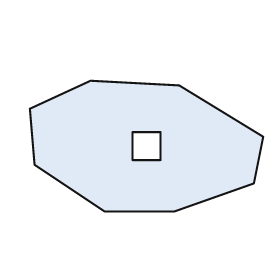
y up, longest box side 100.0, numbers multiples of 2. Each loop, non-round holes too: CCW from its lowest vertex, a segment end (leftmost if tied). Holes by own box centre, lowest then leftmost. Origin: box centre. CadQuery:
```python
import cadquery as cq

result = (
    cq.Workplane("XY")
    .moveTo(-18.0, -28.0)
    .lineTo(12.0, -28.0)
    .lineTo(46.0, -16.0)
    .lineTo(50.0, 4.0)
    .lineTo(14.0, 26.0)
    .lineTo(-24.0, 28.0)
    .lineTo(-50.0, 16.0)
    .lineTo(-48.0, -8.0)
    .close()
    .moveTo(-6.0, -6.0)
    .lineTo(6.0, -6.0)
    .lineTo(6.0, 6.0)
    .lineTo(-6.0, 6.0)
    .close()
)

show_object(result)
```